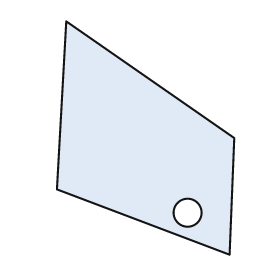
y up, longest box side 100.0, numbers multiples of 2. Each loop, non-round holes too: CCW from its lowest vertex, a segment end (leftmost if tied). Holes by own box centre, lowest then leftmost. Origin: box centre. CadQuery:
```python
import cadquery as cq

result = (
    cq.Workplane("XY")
    .moveTo(36.0, -50.0)
    .lineTo(38.0, 0.0)
    .lineTo(-34.0, 50.0)
    .lineTo(-38.0, -22.0)
    .close()
    .moveTo(18.0, -32.0)
    .circle(6.0)
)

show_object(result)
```